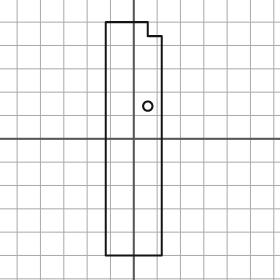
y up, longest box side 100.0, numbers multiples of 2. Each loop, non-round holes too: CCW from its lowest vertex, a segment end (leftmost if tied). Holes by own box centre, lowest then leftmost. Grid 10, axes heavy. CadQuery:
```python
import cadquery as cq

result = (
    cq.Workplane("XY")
    .moveTo(-12.0, -50.0)
    .lineTo(12.0, -50.0)
    .lineTo(12.0, 44.0)
    .lineTo(6.0, 44.0)
    .lineTo(6.0, 50.0)
    .lineTo(-12.0, 50.0)
    .close()
    .moveTo(6.0, 14.0)
    .circle(2.0)
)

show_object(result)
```